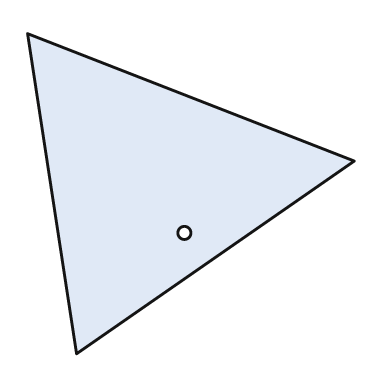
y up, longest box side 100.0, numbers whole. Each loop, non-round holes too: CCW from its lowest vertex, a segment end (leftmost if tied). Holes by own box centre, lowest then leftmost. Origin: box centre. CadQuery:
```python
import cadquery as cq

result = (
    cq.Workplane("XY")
    .moveTo(-35.0, -49.0)
    .lineTo(50.0, 10.0)
    .lineTo(-50.0, 49.0)
    .close()
    .moveTo(-2.0, -12.0)
    .circle(2.0)
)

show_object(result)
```